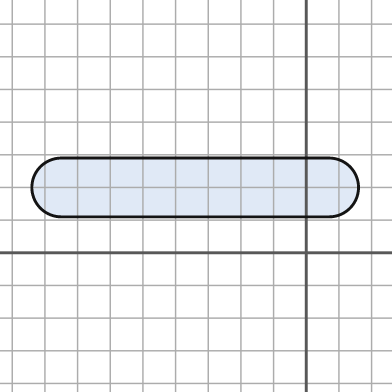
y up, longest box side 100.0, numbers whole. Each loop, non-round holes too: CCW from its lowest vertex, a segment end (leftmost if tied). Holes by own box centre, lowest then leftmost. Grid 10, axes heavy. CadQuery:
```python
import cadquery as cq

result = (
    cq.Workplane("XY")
    .moveTo(-75.0, 11.0)
    .lineTo(7.0, 11.0)
    .threePointArc((16.0, 20.0), (7.0, 29.0))
    .lineTo(-75.0, 29.0)
    .threePointArc((-84.0, 20.0), (-75.0, 11.0))
    .close()
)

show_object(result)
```